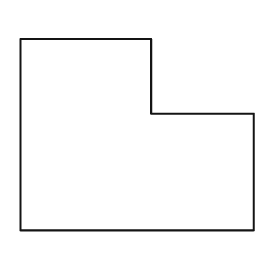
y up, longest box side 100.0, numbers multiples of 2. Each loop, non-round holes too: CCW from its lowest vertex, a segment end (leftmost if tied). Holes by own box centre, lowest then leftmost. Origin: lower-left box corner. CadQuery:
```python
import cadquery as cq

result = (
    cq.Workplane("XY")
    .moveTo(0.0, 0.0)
    .lineTo(100.0, 0.0)
    .lineTo(100.0, 50.0)
    .lineTo(56.0, 50.0)
    .lineTo(56.0, 82.0)
    .lineTo(0.0, 82.0)
    .close()
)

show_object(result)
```